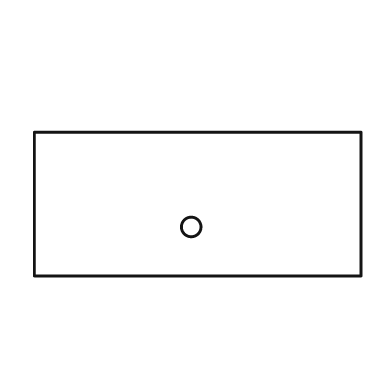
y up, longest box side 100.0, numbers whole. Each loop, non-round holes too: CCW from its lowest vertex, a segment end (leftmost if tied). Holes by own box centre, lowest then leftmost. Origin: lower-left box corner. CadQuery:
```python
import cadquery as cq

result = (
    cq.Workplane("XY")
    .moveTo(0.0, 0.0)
    .lineTo(100.0, 0.0)
    .lineTo(100.0, 44.0)
    .lineTo(0.0, 44.0)
    .close()
    .moveTo(48.0, 15.0)
    .circle(3.0)
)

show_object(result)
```